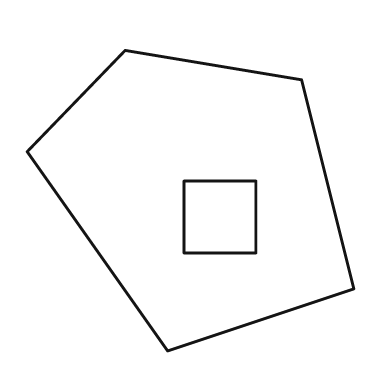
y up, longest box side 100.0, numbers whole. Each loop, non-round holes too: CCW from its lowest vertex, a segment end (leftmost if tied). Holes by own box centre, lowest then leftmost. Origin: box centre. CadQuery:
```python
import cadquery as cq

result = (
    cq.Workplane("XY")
    .moveTo(-7.0, -46.0)
    .lineTo(50.0, -27.0)
    .lineTo(34.0, 37.0)
    .lineTo(-20.0, 46.0)
    .lineTo(-50.0, 15.0)
    .close()
    .moveTo(-2.0, -16.0)
    .lineTo(20.0, -16.0)
    .lineTo(20.0, 6.0)
    .lineTo(-2.0, 6.0)
    .close()
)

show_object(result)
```